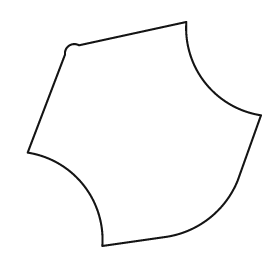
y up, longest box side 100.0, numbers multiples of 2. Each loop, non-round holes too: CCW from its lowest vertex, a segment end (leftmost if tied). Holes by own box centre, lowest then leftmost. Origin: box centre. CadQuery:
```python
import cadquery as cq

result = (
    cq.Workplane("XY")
    .moveTo(-18.0, -48.0)
    .lineTo(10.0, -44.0)
    .threePointArc((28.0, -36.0), (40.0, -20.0))
    .lineTo(50.0, 8.0)
    .threePointArc((26.0, 22.0), (18.0, 48.0))
    .lineTo(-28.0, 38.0)
    .threePointArc((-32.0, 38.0), (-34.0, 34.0))
    .lineTo(-50.0, -8.0)
    .threePointArc((-26.0, -22.0), (-18.0, -48.0))
    .close()
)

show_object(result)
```